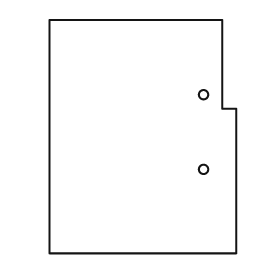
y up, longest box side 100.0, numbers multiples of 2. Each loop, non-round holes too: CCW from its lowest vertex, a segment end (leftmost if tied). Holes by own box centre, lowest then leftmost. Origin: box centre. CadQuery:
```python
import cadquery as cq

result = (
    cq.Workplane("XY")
    .moveTo(-40.0, -50.0)
    .lineTo(40.0, -50.0)
    .lineTo(40.0, 12.0)
    .lineTo(34.0, 12.0)
    .lineTo(34.0, 50.0)
    .lineTo(-40.0, 50.0)
    .close()
    .moveTo(26.0, -14.0)
    .circle(2.0)
    .moveTo(26.0, 18.0)
    .circle(2.0)
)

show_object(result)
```